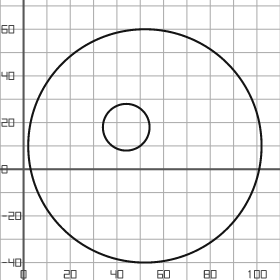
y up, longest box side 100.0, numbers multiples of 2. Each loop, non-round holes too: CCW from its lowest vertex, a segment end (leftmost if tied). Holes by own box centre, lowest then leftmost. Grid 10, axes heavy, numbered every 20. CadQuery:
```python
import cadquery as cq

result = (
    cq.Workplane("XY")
    .moveTo(52.0, 10.0)
    .circle(50.0)
    .moveTo(44.0, 18.0)
    .circle(10.0)
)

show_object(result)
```